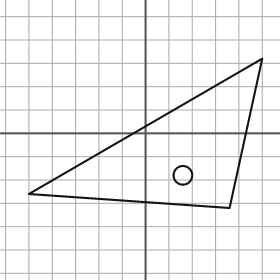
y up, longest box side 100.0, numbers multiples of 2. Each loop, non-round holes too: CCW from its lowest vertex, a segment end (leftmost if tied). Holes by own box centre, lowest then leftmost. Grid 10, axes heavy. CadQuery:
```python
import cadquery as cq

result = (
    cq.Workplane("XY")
    .moveTo(36.0, -32.0)
    .lineTo(50.0, 32.0)
    .lineTo(-50.0, -26.0)
    .close()
    .moveTo(16.0, -18.0)
    .circle(4.0)
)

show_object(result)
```